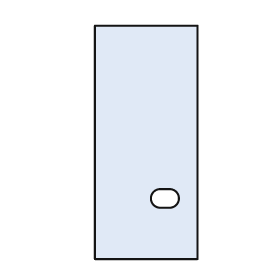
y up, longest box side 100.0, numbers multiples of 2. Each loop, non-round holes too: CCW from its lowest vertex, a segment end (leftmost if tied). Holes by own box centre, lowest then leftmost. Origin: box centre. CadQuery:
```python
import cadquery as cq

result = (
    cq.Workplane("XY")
    .moveTo(-22.0, -50.0)
    .lineTo(22.0, -50.0)
    .lineTo(22.0, 50.0)
    .lineTo(-22.0, 50.0)
    .close()
    .moveTo(6.0, -28.0)
    .lineTo(10.0, -28.0)
    .threePointArc((14.0, -24.0), (10.0, -20.0))
    .lineTo(6.0, -20.0)
    .threePointArc((2.0, -24.0), (6.0, -28.0))
    .close()
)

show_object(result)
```